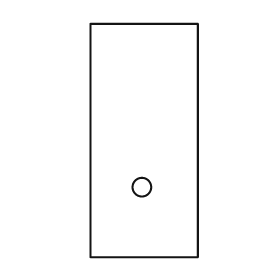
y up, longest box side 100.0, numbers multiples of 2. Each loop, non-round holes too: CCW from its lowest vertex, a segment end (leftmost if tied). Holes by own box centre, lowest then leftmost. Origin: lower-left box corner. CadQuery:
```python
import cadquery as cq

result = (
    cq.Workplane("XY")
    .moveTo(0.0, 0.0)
    .lineTo(46.0, 0.0)
    .lineTo(46.0, 100.0)
    .lineTo(0.0, 100.0)
    .close()
    .moveTo(22.0, 30.0)
    .circle(4.0)
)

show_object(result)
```